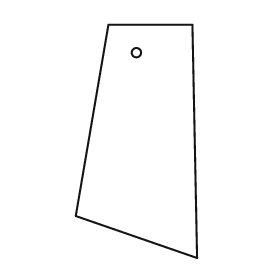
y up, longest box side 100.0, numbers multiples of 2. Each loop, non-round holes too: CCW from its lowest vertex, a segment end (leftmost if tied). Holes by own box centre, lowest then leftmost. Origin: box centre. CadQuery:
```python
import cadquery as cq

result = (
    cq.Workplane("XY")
    .moveTo(26.0, -50.0)
    .lineTo(24.0, 50.0)
    .lineTo(-12.0, 50.0)
    .lineTo(-26.0, -32.0)
    .close()
    .moveTo(0.0, 38.0)
    .circle(2.0)
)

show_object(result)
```